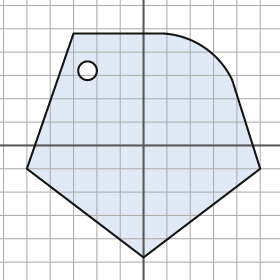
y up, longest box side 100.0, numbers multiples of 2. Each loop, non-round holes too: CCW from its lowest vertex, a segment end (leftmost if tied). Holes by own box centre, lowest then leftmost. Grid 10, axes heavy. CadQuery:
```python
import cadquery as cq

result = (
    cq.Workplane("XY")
    .moveTo(0.0, -48.0)
    .lineTo(50.0, -10.0)
    .lineTo(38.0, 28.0)
    .threePointArc((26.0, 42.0), (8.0, 48.0))
    .lineTo(-30.0, 48.0)
    .lineTo(-50.0, -10.0)
    .close()
    .moveTo(-24.0, 32.0)
    .circle(4.0)
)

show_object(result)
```